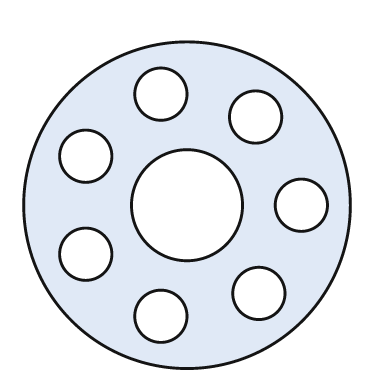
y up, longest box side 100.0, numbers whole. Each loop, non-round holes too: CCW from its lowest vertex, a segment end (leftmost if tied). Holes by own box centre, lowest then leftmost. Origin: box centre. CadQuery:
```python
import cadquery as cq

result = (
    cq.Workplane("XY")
    .moveTo(0.0, 0.0)
    .circle(50.0)
    .moveTo(-8.0, -34.0)
    .circle(8.0)
    .moveTo(22.0, -27.0)
    .circle(8.0)
    .moveTo(-31.0, -15.0)
    .circle(8.0)
    .moveTo(0.0, 0.0)
    .circle(17.0)
    .moveTo(35.0, 0.0)
    .circle(8.0)
    .moveTo(-31.0, 15.0)
    .circle(8.0)
    .moveTo(21.0, 27.0)
    .circle(8.0)
    .moveTo(-8.0, 34.0)
    .circle(8.0)
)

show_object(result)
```